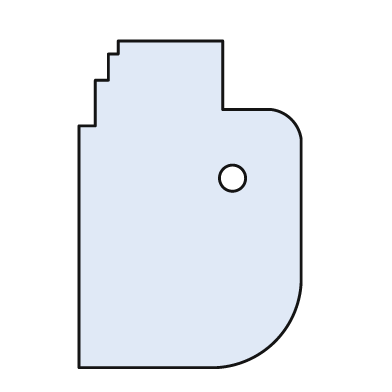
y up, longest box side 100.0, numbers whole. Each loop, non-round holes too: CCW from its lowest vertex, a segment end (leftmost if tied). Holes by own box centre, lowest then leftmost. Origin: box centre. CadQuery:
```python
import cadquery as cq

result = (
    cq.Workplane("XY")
    .moveTo(-34.0, -50.0)
    .lineTo(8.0, -50.0)
    .threePointArc((26.0, -42.0), (34.0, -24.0))
    .lineTo(34.0, 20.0)
    .threePointArc((31.0, 26.0), (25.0, 29.0))
    .lineTo(10.0, 29.0)
    .lineTo(10.0, 50.0)
    .lineTo(-22.0, 50.0)
    .lineTo(-22.0, 46.0)
    .lineTo(-25.0, 46.0)
    .lineTo(-25.0, 38.0)
    .lineTo(-29.0, 38.0)
    .lineTo(-29.0, 24.0)
    .lineTo(-34.0, 24.0)
    .close()
    .moveTo(13.0, 8.0)
    .circle(4.0)
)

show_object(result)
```